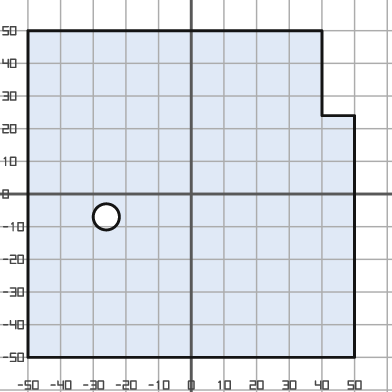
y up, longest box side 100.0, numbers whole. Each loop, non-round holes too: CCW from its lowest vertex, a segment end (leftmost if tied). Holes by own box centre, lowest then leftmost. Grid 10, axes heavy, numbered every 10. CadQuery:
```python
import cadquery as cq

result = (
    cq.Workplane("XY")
    .moveTo(-50.0, -50.0)
    .lineTo(50.0, -50.0)
    .lineTo(50.0, 24.0)
    .lineTo(40.0, 24.0)
    .lineTo(40.0, 50.0)
    .lineTo(-50.0, 50.0)
    .close()
    .moveTo(-26.0, -7.0)
    .circle(4.0)
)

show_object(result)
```